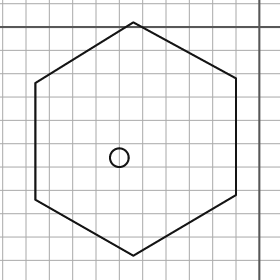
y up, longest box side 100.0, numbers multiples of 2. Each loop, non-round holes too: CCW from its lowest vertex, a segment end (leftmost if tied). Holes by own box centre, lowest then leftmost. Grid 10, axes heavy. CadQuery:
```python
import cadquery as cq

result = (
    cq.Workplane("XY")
    .moveTo(-54.0, -98.0)
    .lineTo(-10.0, -72.0)
    .lineTo(-10.0, -22.0)
    .lineTo(-54.0, 2.0)
    .lineTo(-96.0, -24.0)
    .lineTo(-96.0, -74.0)
    .close()
    .moveTo(-60.0, -56.0)
    .circle(4.0)
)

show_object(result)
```